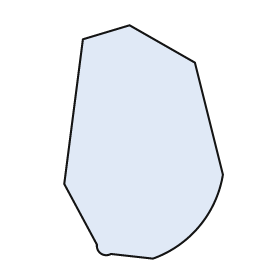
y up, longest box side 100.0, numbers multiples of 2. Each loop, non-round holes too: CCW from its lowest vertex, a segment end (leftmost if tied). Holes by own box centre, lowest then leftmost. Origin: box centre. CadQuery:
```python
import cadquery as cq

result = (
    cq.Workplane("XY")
    .moveTo(4.0, -50.0)
    .threePointArc((24.0, -36.0), (34.0, -14.0))
    .lineTo(22.0, 34.0)
    .lineTo(-6.0, 50.0)
    .lineTo(-26.0, 44.0)
    .lineTo(-34.0, -18.0)
    .lineTo(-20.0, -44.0)
    .threePointArc((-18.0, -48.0), (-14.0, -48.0))
    .close()
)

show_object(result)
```